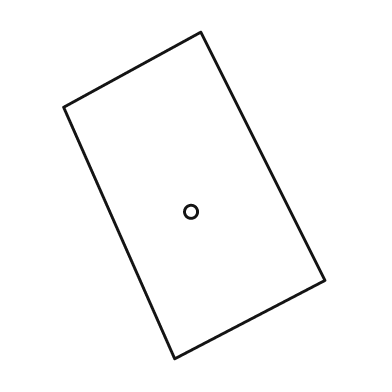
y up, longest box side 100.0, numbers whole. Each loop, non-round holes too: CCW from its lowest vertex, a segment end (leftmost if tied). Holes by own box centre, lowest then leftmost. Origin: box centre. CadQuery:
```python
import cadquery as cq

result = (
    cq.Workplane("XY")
    .moveTo(-6.0, -50.0)
    .lineTo(40.0, -26.0)
    .lineTo(2.0, 50.0)
    .lineTo(-40.0, 27.0)
    .close()
    .moveTo(-1.0, -5.0)
    .circle(2.0)
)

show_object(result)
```